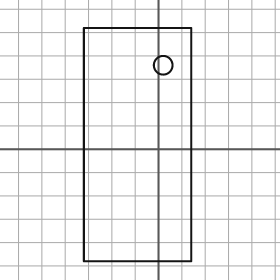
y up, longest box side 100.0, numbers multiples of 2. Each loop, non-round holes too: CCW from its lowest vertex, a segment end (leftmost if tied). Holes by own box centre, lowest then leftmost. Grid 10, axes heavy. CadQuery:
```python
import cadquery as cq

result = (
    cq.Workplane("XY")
    .moveTo(-32.0, -48.0)
    .lineTo(14.0, -48.0)
    .lineTo(14.0, 52.0)
    .lineTo(-32.0, 52.0)
    .close()
    .moveTo(2.0, 36.0)
    .circle(4.0)
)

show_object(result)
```